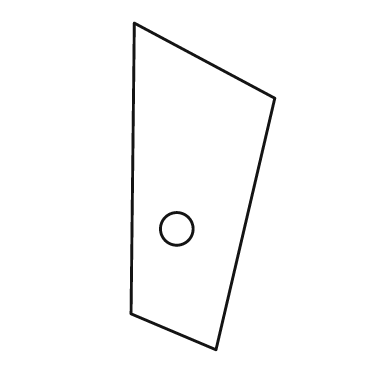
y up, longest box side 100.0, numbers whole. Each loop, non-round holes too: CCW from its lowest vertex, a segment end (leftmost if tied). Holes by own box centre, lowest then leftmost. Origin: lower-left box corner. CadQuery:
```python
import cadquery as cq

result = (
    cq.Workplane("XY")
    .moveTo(26.0, 0.0)
    .lineTo(44.0, 77.0)
    .lineTo(1.0, 100.0)
    .lineTo(0.0, 11.0)
    .close()
    .moveTo(14.0, 37.0)
    .circle(5.0)
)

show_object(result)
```